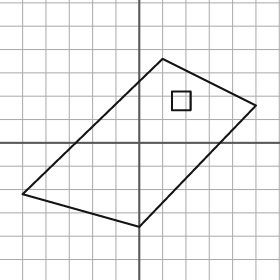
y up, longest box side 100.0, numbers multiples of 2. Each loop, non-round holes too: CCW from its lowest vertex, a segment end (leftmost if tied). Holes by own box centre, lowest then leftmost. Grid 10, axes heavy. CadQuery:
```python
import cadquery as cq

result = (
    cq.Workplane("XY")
    .moveTo(0.0, -36.0)
    .lineTo(50.0, 16.0)
    .lineTo(10.0, 36.0)
    .lineTo(-50.0, -22.0)
    .close()
    .moveTo(14.0, 14.0)
    .lineTo(22.0, 14.0)
    .lineTo(22.0, 22.0)
    .lineTo(14.0, 22.0)
    .close()
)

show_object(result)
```